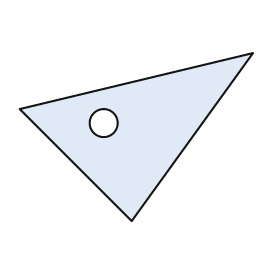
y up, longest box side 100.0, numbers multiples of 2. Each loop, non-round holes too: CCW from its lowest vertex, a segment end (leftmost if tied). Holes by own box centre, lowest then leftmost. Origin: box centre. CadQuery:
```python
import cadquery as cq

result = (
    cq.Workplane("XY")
    .moveTo(-2.0, -36.0)
    .lineTo(50.0, 36.0)
    .lineTo(-50.0, 12.0)
    .close()
    .moveTo(-14.0, 6.0)
    .circle(6.0)
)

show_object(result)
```